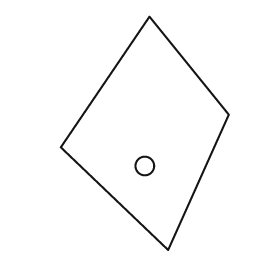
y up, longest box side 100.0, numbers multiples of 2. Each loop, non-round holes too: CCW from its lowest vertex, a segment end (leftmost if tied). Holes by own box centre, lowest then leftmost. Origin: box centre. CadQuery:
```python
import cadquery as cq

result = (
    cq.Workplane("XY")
    .moveTo(10.0, -50.0)
    .lineTo(36.0, 8.0)
    .lineTo(2.0, 50.0)
    .lineTo(-36.0, -6.0)
    .close()
    .moveTo(0.0, -14.0)
    .circle(4.0)
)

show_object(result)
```